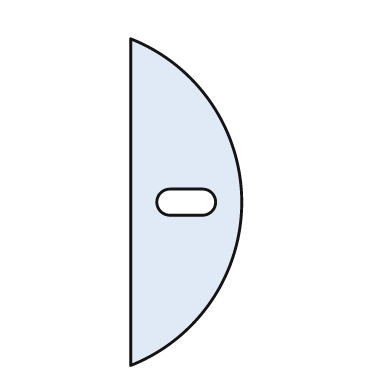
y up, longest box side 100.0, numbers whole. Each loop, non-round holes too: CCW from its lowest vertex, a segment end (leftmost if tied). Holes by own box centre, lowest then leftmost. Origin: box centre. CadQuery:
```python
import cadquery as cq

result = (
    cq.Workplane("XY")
    .moveTo(-17.0, -50.0)
    .threePointArc((17.0, 0.0), (-17.0, 50.0))
    .close()
    .moveTo(-5.0, -4.0)
    .lineTo(5.0, -4.0)
    .threePointArc((9.0, 0.0), (5.0, 4.0))
    .lineTo(-5.0, 4.0)
    .threePointArc((-9.0, 0.0), (-5.0, -4.0))
    .close()
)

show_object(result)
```